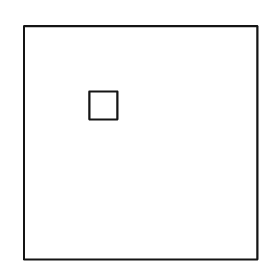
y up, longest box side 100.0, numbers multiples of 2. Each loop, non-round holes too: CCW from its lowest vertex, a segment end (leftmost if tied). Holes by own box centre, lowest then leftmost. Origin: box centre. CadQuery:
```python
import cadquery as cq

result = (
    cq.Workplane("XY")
    .moveTo(-50.0, -50.0)
    .lineTo(50.0, -50.0)
    .lineTo(50.0, 50.0)
    .lineTo(-50.0, 50.0)
    .close()
    .moveTo(-22.0, 10.0)
    .lineTo(-10.0, 10.0)
    .lineTo(-10.0, 22.0)
    .lineTo(-22.0, 22.0)
    .close()
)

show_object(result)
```